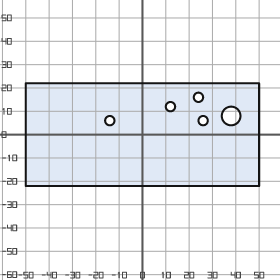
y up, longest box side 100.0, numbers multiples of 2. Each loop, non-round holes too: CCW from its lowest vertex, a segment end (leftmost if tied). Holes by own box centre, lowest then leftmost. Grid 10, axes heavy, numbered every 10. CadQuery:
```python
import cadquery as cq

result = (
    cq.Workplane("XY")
    .moveTo(-50.0, -22.0)
    .lineTo(50.0, -22.0)
    .lineTo(50.0, 22.0)
    .lineTo(-50.0, 22.0)
    .close()
    .moveTo(-14.0, 6.0)
    .circle(2.0)
    .moveTo(26.0, 6.0)
    .circle(2.0)
    .moveTo(38.0, 8.0)
    .circle(4.0)
    .moveTo(12.0, 12.0)
    .circle(2.0)
    .moveTo(24.0, 16.0)
    .circle(2.0)
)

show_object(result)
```